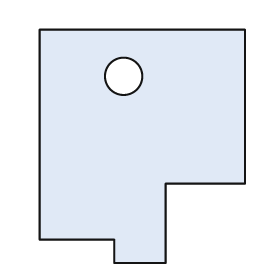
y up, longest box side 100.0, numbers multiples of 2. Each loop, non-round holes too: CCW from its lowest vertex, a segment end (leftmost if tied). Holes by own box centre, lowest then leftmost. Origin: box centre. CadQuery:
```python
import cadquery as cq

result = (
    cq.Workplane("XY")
    .moveTo(-12.0, -50.0)
    .lineTo(10.0, -50.0)
    .lineTo(10.0, -16.0)
    .lineTo(44.0, -16.0)
    .lineTo(44.0, 50.0)
    .lineTo(-44.0, 50.0)
    .lineTo(-44.0, -40.0)
    .lineTo(-12.0, -40.0)
    .close()
    .moveTo(-8.0, 30.0)
    .circle(8.0)
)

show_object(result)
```